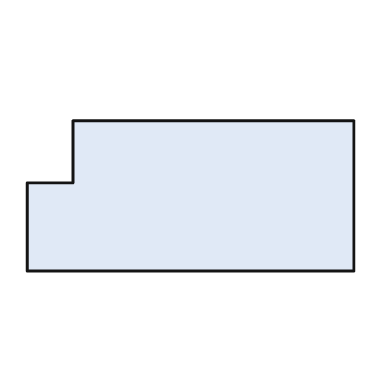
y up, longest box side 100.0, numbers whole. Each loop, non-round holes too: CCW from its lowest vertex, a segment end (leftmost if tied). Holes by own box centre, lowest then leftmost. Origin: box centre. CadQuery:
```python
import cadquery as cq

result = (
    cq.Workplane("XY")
    .moveTo(-50.0, -23.0)
    .lineTo(50.0, -23.0)
    .lineTo(50.0, 23.0)
    .lineTo(-36.0, 23.0)
    .lineTo(-36.0, 4.0)
    .lineTo(-50.0, 4.0)
    .close()
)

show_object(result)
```